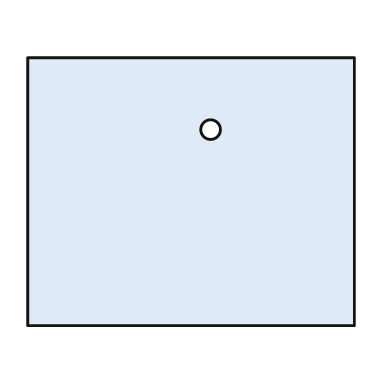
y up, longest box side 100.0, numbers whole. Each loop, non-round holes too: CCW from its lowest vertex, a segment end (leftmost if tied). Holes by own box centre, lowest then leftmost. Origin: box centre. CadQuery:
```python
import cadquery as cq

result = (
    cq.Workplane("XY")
    .moveTo(-50.0, -41.0)
    .lineTo(50.0, -41.0)
    .lineTo(50.0, 41.0)
    .lineTo(-50.0, 41.0)
    .close()
    .moveTo(6.0, 19.0)
    .circle(3.0)
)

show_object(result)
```